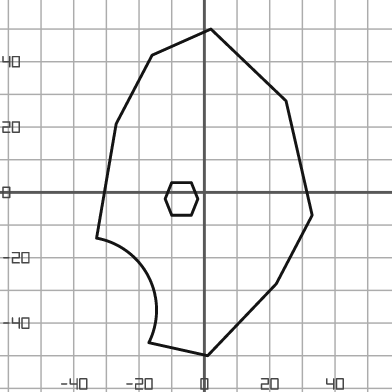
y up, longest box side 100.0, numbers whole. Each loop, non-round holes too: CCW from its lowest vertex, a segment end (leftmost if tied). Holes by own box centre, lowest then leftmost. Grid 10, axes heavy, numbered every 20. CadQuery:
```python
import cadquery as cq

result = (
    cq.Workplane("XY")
    .moveTo(1.0, -50.0)
    .lineTo(22.0, -28.0)
    .lineTo(33.0, -7.0)
    .lineTo(25.0, 28.0)
    .lineTo(2.0, 50.0)
    .lineTo(-16.0, 42.0)
    .lineTo(-27.0, 21.0)
    .lineTo(-33.0, -14.0)
    .threePointArc((-17.0, -26.0), (-17.0, -46.0))
    .close()
    .moveTo(-10.0, -7.0)
    .lineTo(-4.0, -7.0)
    .lineTo(-2.0, -2.0)
    .lineTo(-4.0, 3.0)
    .lineTo(-10.0, 3.0)
    .lineTo(-12.0, -2.0)
    .close()
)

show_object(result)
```